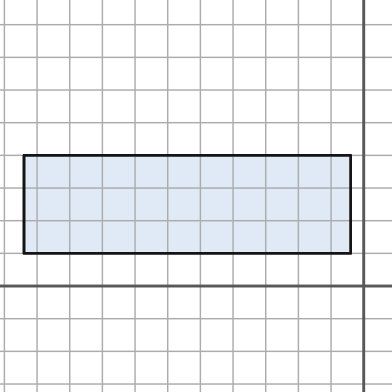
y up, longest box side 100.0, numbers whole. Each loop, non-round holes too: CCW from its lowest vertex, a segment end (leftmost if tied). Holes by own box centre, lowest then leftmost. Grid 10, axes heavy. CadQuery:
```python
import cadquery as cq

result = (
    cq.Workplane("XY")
    .moveTo(-104.0, 10.0)
    .lineTo(-4.0, 10.0)
    .lineTo(-4.0, 40.0)
    .lineTo(-104.0, 40.0)
    .close()
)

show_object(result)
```